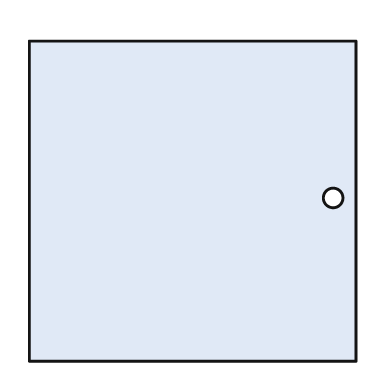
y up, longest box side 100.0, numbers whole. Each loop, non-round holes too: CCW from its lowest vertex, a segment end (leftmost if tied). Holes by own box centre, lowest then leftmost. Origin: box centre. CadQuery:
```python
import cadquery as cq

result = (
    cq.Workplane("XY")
    .moveTo(-50.0, -49.0)
    .lineTo(50.0, -49.0)
    .lineTo(50.0, 49.0)
    .lineTo(-50.0, 49.0)
    .close()
    .moveTo(43.0, 1.0)
    .circle(3.0)
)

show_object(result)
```